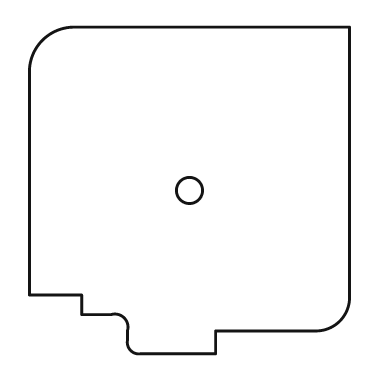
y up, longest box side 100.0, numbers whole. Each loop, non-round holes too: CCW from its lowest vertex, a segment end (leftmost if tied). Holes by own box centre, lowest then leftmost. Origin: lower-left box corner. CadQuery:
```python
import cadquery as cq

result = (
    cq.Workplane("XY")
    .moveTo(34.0, 0.0)
    .lineTo(57.0, 0.0)
    .lineTo(57.0, 7.0)
    .lineTo(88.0, 7.0)
    .threePointArc((95.0, 10.0), (98.0, 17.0))
    .lineTo(98.0, 100.0)
    .lineTo(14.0, 100.0)
    .threePointArc((4.0, 96.0), (0.0, 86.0))
    .lineTo(0.0, 18.0)
    .lineTo(16.0, 18.0)
    .lineTo(16.0, 12.0)
    .lineTo(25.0, 12.0)
    .threePointArc((29.0, 11.0), (30.0, 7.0))
    .lineTo(30.0, 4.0)
    .threePointArc((31.0, 1.0), (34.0, 0.0))
    .close()
    .moveTo(49.0, 50.0)
    .circle(4.0)
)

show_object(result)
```